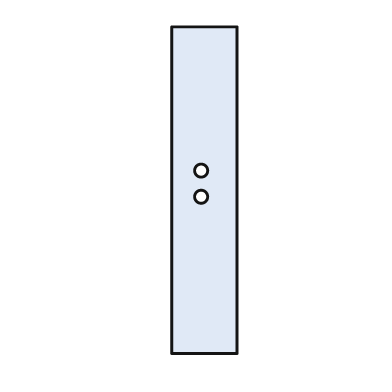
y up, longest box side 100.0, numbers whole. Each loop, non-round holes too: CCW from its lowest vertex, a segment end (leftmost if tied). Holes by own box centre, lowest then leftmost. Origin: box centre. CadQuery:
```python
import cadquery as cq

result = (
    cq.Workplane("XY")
    .moveTo(-10.0, -50.0)
    .lineTo(10.0, -50.0)
    .lineTo(10.0, 50.0)
    .lineTo(-10.0, 50.0)
    .close()
    .moveTo(-1.0, -2.0)
    .circle(2.0)
    .moveTo(-1.0, 6.0)
    .circle(2.0)
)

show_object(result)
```